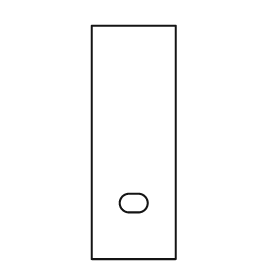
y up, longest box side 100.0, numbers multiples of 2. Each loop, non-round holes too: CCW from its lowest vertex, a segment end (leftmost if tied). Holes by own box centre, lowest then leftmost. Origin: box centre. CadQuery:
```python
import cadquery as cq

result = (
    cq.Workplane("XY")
    .moveTo(-18.0, -50.0)
    .lineTo(18.0, -50.0)
    .lineTo(18.0, 50.0)
    .lineTo(-18.0, 50.0)
    .close()
    .moveTo(-2.0, -30.0)
    .lineTo(2.0, -30.0)
    .threePointArc((6.0, -26.0), (2.0, -22.0))
    .lineTo(-2.0, -22.0)
    .threePointArc((-6.0, -26.0), (-2.0, -30.0))
    .close()
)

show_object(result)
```